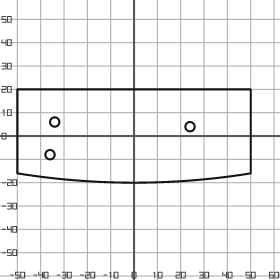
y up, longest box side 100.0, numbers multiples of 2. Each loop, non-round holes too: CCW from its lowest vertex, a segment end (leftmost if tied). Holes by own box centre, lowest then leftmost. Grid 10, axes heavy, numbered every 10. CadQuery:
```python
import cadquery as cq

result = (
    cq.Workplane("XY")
    .moveTo(-50.0, -16.0)
    .threePointArc((0.0, -20.0), (50.0, -16.0))
    .lineTo(50.0, 20.0)
    .lineTo(-50.0, 20.0)
    .close()
    .moveTo(-36.0, -8.0)
    .circle(2.0)
    .moveTo(24.0, 4.0)
    .circle(2.0)
    .moveTo(-34.0, 6.0)
    .circle(2.0)
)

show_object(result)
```